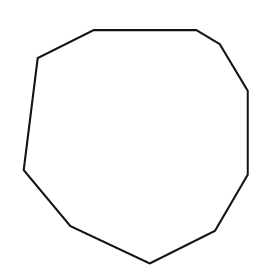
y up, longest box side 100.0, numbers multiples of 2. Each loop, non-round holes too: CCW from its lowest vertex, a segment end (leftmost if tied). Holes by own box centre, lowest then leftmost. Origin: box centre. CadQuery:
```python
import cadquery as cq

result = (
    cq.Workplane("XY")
    .moveTo(6.0, -50.0)
    .lineTo(34.0, -36.0)
    .lineTo(48.0, -12.0)
    .lineTo(48.0, 24.0)
    .lineTo(36.0, 44.0)
    .lineTo(26.0, 50.0)
    .lineTo(-18.0, 50.0)
    .lineTo(-42.0, 38.0)
    .lineTo(-48.0, -10.0)
    .lineTo(-28.0, -34.0)
    .close()
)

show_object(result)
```